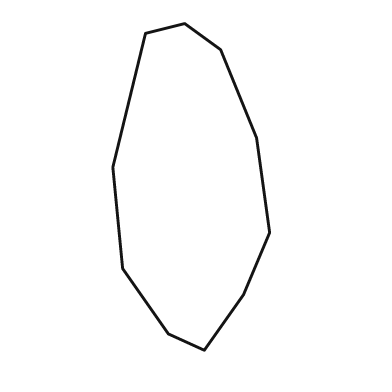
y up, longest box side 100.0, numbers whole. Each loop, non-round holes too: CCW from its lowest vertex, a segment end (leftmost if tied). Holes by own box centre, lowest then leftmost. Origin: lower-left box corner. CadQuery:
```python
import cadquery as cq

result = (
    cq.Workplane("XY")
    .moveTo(28.0, 0.0)
    .lineTo(40.0, 17.0)
    .lineTo(48.0, 36.0)
    .lineTo(44.0, 65.0)
    .lineTo(33.0, 92.0)
    .lineTo(22.0, 100.0)
    .lineTo(10.0, 97.0)
    .lineTo(0.0, 56.0)
    .lineTo(3.0, 25.0)
    .lineTo(17.0, 5.0)
    .close()
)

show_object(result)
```